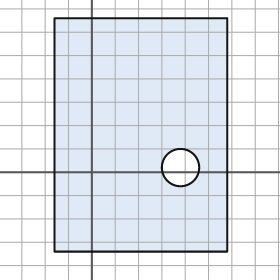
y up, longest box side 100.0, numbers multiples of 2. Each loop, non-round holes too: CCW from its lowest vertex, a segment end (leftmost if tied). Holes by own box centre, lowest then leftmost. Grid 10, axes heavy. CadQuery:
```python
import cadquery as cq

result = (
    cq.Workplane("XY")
    .moveTo(-16.0, -34.0)
    .lineTo(58.0, -34.0)
    .lineTo(58.0, 66.0)
    .lineTo(-16.0, 66.0)
    .close()
    .moveTo(38.0, 2.0)
    .circle(8.0)
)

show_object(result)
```